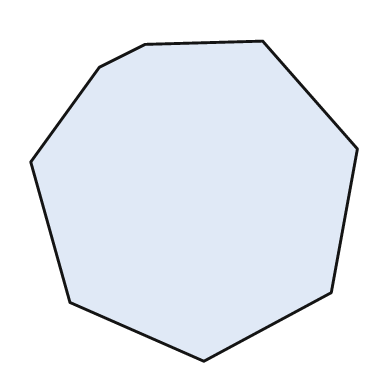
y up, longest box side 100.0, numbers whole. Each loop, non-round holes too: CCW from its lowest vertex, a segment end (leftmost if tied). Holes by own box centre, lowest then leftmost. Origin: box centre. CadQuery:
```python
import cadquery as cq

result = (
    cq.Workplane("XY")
    .moveTo(3.0, -49.0)
    .lineTo(42.0, -28.0)
    .lineTo(50.0, 16.0)
    .lineTo(21.0, 49.0)
    .lineTo(-15.0, 48.0)
    .lineTo(-29.0, 41.0)
    .lineTo(-50.0, 12.0)
    .lineTo(-38.0, -31.0)
    .close()
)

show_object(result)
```